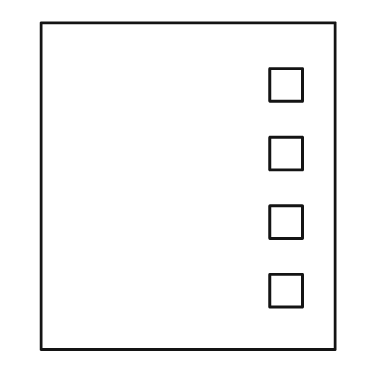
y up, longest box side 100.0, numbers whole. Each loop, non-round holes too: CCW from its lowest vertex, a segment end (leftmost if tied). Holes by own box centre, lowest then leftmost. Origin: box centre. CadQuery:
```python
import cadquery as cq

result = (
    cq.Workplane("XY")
    .moveTo(-45.0, -50.0)
    .lineTo(45.0, -50.0)
    .lineTo(45.0, 50.0)
    .lineTo(-45.0, 50.0)
    .close()
    .moveTo(25.0, -37.0)
    .lineTo(35.0, -37.0)
    .lineTo(35.0, -27.0)
    .lineTo(25.0, -27.0)
    .close()
    .moveTo(25.0, -16.0)
    .lineTo(35.0, -16.0)
    .lineTo(35.0, -6.0)
    .lineTo(25.0, -6.0)
    .close()
    .moveTo(25.0, 5.0)
    .lineTo(35.0, 5.0)
    .lineTo(35.0, 15.0)
    .lineTo(25.0, 15.0)
    .close()
    .moveTo(25.0, 26.0)
    .lineTo(35.0, 26.0)
    .lineTo(35.0, 36.0)
    .lineTo(25.0, 36.0)
    .close()
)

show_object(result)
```